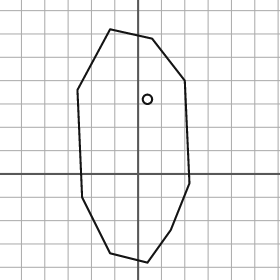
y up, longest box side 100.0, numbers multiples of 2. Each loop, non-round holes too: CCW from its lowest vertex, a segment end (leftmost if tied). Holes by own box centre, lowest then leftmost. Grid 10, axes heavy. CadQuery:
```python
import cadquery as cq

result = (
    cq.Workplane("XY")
    .moveTo(4.0, -38.0)
    .lineTo(14.0, -24.0)
    .lineTo(22.0, -4.0)
    .lineTo(20.0, 40.0)
    .lineTo(6.0, 58.0)
    .lineTo(-12.0, 62.0)
    .lineTo(-26.0, 36.0)
    .lineTo(-24.0, -10.0)
    .lineTo(-12.0, -34.0)
    .close()
    .moveTo(4.0, 32.0)
    .circle(2.0)
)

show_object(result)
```